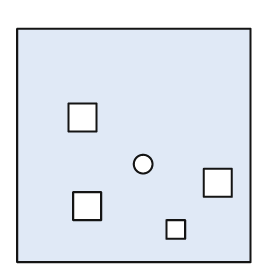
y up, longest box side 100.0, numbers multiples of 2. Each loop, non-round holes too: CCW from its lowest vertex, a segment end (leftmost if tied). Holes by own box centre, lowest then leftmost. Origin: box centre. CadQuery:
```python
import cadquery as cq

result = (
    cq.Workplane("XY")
    .moveTo(-50.0, -50.0)
    .lineTo(50.0, -50.0)
    .lineTo(50.0, 50.0)
    .lineTo(-50.0, 50.0)
    .close()
    .moveTo(14.0, -40.0)
    .lineTo(22.0, -40.0)
    .lineTo(22.0, -32.0)
    .lineTo(14.0, -32.0)
    .close()
    .moveTo(-26.0, -32.0)
    .lineTo(-14.0, -32.0)
    .lineTo(-14.0, -20.0)
    .lineTo(-26.0, -20.0)
    .close()
    .moveTo(30.0, -22.0)
    .lineTo(42.0, -22.0)
    .lineTo(42.0, -10.0)
    .lineTo(30.0, -10.0)
    .close()
    .moveTo(4.0, -8.0)
    .circle(4.0)
    .moveTo(-28.0, 6.0)
    .lineTo(-16.0, 6.0)
    .lineTo(-16.0, 18.0)
    .lineTo(-28.0, 18.0)
    .close()
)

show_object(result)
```